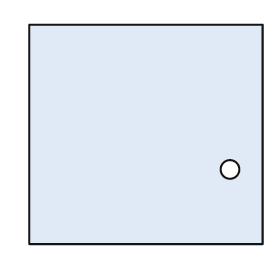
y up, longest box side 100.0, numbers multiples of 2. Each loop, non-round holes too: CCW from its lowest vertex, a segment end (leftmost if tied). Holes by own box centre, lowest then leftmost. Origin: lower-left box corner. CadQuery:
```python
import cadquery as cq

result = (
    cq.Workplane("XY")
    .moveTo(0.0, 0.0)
    .lineTo(100.0, 0.0)
    .lineTo(100.0, 94.0)
    .lineTo(0.0, 94.0)
    .close()
    .moveTo(86.0, 32.0)
    .circle(4.0)
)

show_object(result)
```